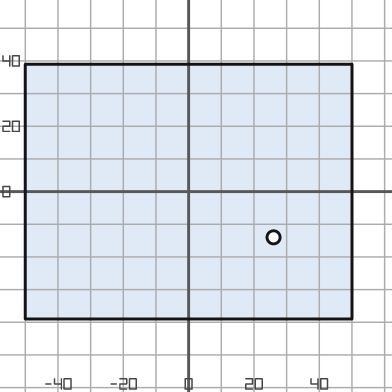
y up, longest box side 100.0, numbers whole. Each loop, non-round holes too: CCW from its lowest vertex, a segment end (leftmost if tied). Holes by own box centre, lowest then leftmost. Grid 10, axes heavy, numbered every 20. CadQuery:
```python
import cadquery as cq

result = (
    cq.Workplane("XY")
    .moveTo(-50.0, -39.0)
    .lineTo(50.0, -39.0)
    .lineTo(50.0, 39.0)
    .lineTo(-50.0, 39.0)
    .close()
    .moveTo(26.0, -14.0)
    .circle(2.0)
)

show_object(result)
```